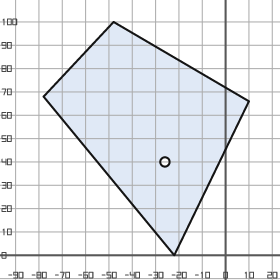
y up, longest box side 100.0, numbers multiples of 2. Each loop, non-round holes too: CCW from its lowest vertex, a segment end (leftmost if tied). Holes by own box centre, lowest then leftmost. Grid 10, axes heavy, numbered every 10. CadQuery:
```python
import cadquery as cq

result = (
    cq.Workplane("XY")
    .moveTo(-22.0, 0.0)
    .lineTo(10.0, 66.0)
    .lineTo(-48.0, 100.0)
    .lineTo(-78.0, 68.0)
    .close()
    .moveTo(-26.0, 40.0)
    .circle(2.0)
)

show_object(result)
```